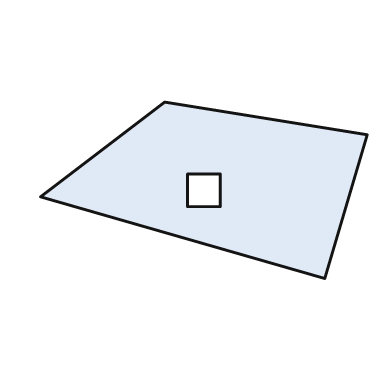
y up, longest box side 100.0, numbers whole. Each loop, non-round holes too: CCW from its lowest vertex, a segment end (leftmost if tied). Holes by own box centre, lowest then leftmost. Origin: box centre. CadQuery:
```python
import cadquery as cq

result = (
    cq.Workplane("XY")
    .moveTo(37.0, -27.0)
    .lineTo(50.0, 17.0)
    .lineTo(-12.0, 27.0)
    .lineTo(-50.0, -2.0)
    .close()
    .moveTo(-5.0, -5.0)
    .lineTo(5.0, -5.0)
    .lineTo(5.0, 5.0)
    .lineTo(-5.0, 5.0)
    .close()
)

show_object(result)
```